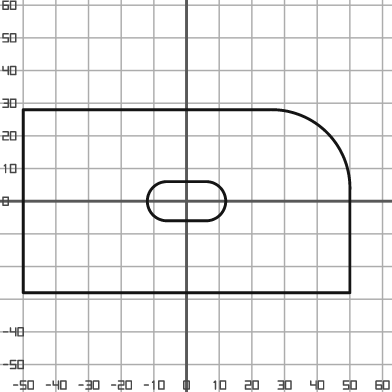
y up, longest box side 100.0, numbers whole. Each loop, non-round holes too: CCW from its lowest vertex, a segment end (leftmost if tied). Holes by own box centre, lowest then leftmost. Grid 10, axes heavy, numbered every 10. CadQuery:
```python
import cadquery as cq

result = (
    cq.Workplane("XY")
    .moveTo(-50.0, -28.0)
    .lineTo(50.0, -28.0)
    .lineTo(50.0, 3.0)
    .threePointArc((43.0, 21.0), (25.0, 28.0))
    .lineTo(-50.0, 28.0)
    .close()
    .moveTo(-6.0, -6.0)
    .lineTo(6.0, -6.0)
    .threePointArc((12.0, 0.0), (6.0, 6.0))
    .lineTo(-6.0, 6.0)
    .threePointArc((-12.0, 0.0), (-6.0, -6.0))
    .close()
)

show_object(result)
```